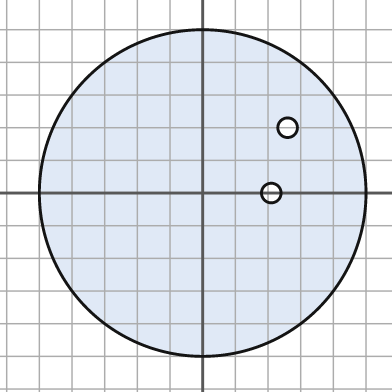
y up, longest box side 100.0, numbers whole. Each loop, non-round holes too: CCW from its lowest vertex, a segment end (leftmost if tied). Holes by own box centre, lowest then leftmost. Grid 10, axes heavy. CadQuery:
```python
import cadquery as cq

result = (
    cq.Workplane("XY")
    .moveTo(0.0, 0.0)
    .circle(50.0)
    .moveTo(21.0, 0.0)
    .circle(3.0)
    .moveTo(26.0, 20.0)
    .circle(3.0)
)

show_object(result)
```